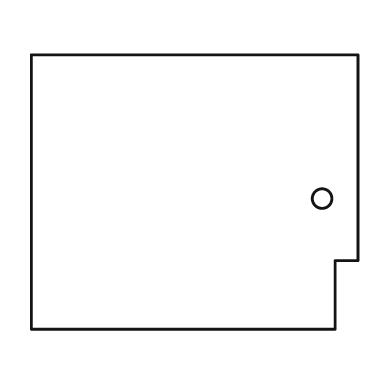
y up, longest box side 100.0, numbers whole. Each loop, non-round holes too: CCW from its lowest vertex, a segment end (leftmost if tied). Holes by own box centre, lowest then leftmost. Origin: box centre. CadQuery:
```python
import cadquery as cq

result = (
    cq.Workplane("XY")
    .moveTo(-50.0, -42.0)
    .lineTo(43.0, -42.0)
    .lineTo(43.0, -21.0)
    .lineTo(50.0, -21.0)
    .lineTo(50.0, 42.0)
    .lineTo(-50.0, 42.0)
    .close()
    .moveTo(39.0, -2.0)
    .circle(3.0)
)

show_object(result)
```